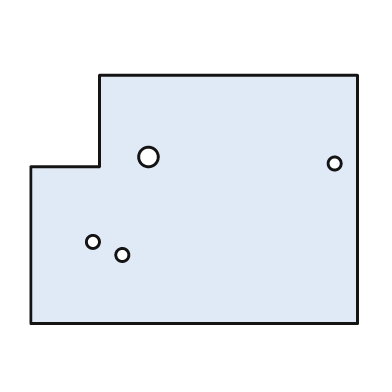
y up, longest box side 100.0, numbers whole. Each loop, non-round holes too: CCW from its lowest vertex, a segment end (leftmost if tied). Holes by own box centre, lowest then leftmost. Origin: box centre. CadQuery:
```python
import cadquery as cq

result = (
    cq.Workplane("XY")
    .moveTo(-50.0, -38.0)
    .lineTo(50.0, -38.0)
    .lineTo(50.0, 38.0)
    .lineTo(-29.0, 38.0)
    .lineTo(-29.0, 10.0)
    .lineTo(-50.0, 10.0)
    .close()
    .moveTo(-22.0, -17.0)
    .circle(2.0)
    .moveTo(-31.0, -13.0)
    .circle(2.0)
    .moveTo(43.0, 11.0)
    .circle(2.0)
    .moveTo(-14.0, 13.0)
    .circle(3.0)
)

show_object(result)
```